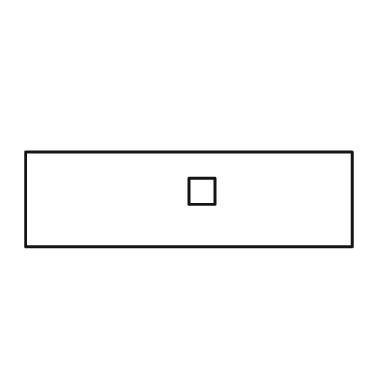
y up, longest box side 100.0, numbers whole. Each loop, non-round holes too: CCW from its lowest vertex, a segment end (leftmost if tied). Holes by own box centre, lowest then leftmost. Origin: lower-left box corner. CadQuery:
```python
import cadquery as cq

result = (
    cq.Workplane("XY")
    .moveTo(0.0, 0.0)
    .lineTo(100.0, 0.0)
    .lineTo(100.0, 29.0)
    .lineTo(0.0, 29.0)
    .close()
    .moveTo(50.0, 13.0)
    .lineTo(58.0, 13.0)
    .lineTo(58.0, 21.0)
    .lineTo(50.0, 21.0)
    .close()
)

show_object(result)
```